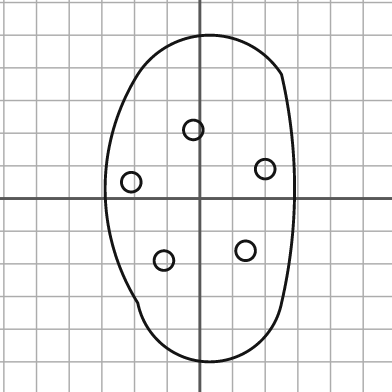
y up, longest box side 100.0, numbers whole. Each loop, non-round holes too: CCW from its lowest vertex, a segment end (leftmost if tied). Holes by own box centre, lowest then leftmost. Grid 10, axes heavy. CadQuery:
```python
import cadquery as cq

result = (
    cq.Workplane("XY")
    .moveTo(-19.0, -32.0)
    .threePointArc((3.0, -50.0), (25.0, -32.0))
    .threePointArc((29.0, 3.0), (25.0, 38.0))
    .threePointArc((3.0, 50.0), (-19.0, 38.0))
    .threePointArc((-29.0, 3.0), (-19.0, -32.0))
    .close()
    .moveTo(-11.0, -19.0)
    .circle(3.0)
    .moveTo(14.0, -16.0)
    .circle(3.0)
    .moveTo(-21.0, 5.0)
    .circle(3.0)
    .moveTo(20.0, 9.0)
    .circle(3.0)
    .moveTo(-2.0, 21.0)
    .circle(3.0)
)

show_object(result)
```